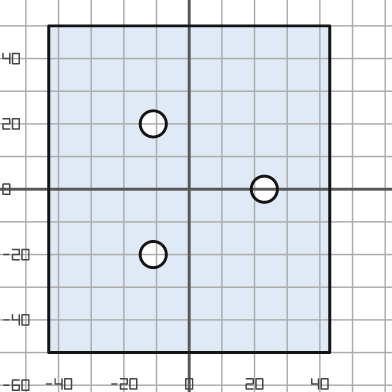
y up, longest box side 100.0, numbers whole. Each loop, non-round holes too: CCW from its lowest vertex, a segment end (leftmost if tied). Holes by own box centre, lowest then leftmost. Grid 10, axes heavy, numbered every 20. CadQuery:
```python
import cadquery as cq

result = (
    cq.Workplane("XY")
    .moveTo(-43.0, -50.0)
    .lineTo(43.0, -50.0)
    .lineTo(43.0, 50.0)
    .lineTo(-43.0, 50.0)
    .close()
    .moveTo(-11.0, -20.0)
    .circle(4.0)
    .moveTo(23.0, 0.0)
    .circle(4.0)
    .moveTo(-11.0, 20.0)
    .circle(4.0)
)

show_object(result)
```